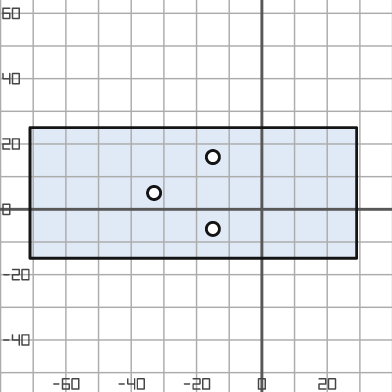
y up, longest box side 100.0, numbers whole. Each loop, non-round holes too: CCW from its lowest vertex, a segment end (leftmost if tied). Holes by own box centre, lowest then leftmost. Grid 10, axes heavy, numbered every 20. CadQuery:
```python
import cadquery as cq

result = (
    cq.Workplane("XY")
    .moveTo(-71.0, -15.0)
    .lineTo(29.0, -15.0)
    .lineTo(29.0, 25.0)
    .lineTo(-71.0, 25.0)
    .close()
    .moveTo(-15.0, -6.0)
    .circle(2.0)
    .moveTo(-33.0, 5.0)
    .circle(2.0)
    .moveTo(-15.0, 16.0)
    .circle(2.0)
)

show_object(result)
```